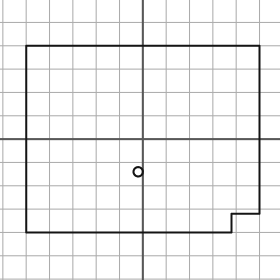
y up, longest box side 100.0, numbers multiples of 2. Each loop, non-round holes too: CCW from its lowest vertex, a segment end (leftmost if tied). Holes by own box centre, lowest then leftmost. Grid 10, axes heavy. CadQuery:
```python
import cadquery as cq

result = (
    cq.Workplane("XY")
    .moveTo(-50.0, -40.0)
    .lineTo(38.0, -40.0)
    .lineTo(38.0, -32.0)
    .lineTo(50.0, -32.0)
    .lineTo(50.0, 40.0)
    .lineTo(-50.0, 40.0)
    .close()
    .moveTo(-2.0, -14.0)
    .circle(2.0)
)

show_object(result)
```